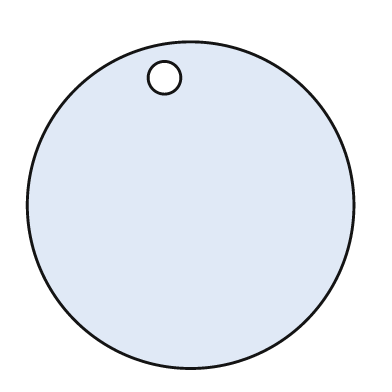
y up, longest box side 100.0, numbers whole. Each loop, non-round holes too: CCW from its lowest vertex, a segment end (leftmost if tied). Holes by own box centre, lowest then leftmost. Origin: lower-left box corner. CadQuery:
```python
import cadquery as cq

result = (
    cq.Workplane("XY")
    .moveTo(50.0, 50.0)
    .circle(50.0)
    .moveTo(42.0, 89.0)
    .circle(5.0)
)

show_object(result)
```